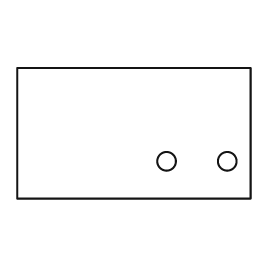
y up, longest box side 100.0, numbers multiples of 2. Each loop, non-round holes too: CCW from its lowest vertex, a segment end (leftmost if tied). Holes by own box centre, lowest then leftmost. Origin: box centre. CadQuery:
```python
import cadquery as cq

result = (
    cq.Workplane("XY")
    .moveTo(-50.0, -28.0)
    .lineTo(50.0, -28.0)
    .lineTo(50.0, 28.0)
    .lineTo(-50.0, 28.0)
    .close()
    .moveTo(14.0, -12.0)
    .circle(4.0)
    .moveTo(40.0, -12.0)
    .circle(4.0)
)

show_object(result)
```